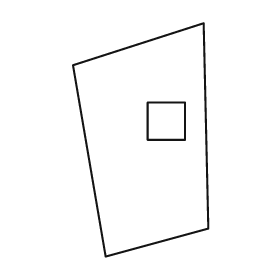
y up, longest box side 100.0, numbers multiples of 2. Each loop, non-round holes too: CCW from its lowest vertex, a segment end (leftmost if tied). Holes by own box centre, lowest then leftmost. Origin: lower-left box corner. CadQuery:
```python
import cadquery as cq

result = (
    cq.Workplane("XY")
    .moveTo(14.0, 0.0)
    .lineTo(58.0, 12.0)
    .lineTo(56.0, 100.0)
    .lineTo(0.0, 82.0)
    .close()
    .moveTo(32.0, 50.0)
    .lineTo(48.0, 50.0)
    .lineTo(48.0, 66.0)
    .lineTo(32.0, 66.0)
    .close()
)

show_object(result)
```